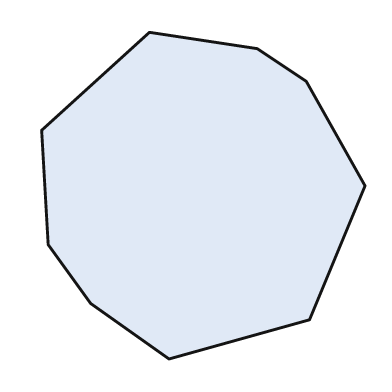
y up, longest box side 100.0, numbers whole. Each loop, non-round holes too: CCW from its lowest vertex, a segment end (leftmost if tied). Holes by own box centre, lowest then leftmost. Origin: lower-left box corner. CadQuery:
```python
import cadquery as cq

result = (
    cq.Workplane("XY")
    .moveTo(39.0, 0.0)
    .lineTo(82.0, 12.0)
    .lineTo(99.0, 53.0)
    .lineTo(81.0, 85.0)
    .lineTo(66.0, 95.0)
    .lineTo(33.0, 100.0)
    .lineTo(0.0, 70.0)
    .lineTo(2.0, 35.0)
    .lineTo(15.0, 17.0)
    .close()
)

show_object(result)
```